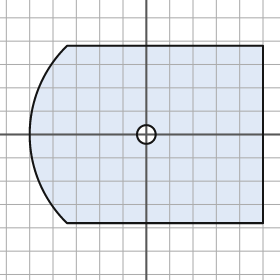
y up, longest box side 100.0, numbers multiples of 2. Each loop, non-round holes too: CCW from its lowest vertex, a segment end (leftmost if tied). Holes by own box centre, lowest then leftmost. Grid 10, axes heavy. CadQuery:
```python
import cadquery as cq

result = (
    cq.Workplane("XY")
    .moveTo(-34.0, -38.0)
    .lineTo(50.0, -38.0)
    .lineTo(50.0, 38.0)
    .lineTo(-34.0, 38.0)
    .threePointArc((-50.0, 0.0), (-34.0, -38.0))
    .close()
    .moveTo(0.0, 0.0)
    .circle(4.0)
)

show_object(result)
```